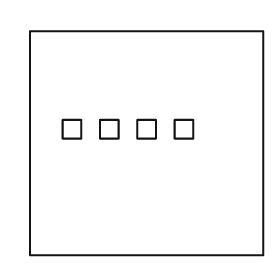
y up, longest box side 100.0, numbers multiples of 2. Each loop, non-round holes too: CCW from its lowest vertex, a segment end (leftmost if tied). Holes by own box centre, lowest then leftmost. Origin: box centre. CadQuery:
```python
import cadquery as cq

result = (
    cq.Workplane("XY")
    .moveTo(-50.0, -48.0)
    .lineTo(50.0, -48.0)
    .lineTo(50.0, 48.0)
    .lineTo(-50.0, 48.0)
    .close()
    .moveTo(-36.0, 2.0)
    .lineTo(-28.0, 2.0)
    .lineTo(-28.0, 10.0)
    .lineTo(-36.0, 10.0)
    .close()
    .moveTo(-20.0, 2.0)
    .lineTo(-12.0, 2.0)
    .lineTo(-12.0, 10.0)
    .lineTo(-20.0, 10.0)
    .close()
    .moveTo(-4.0, 2.0)
    .lineTo(4.0, 2.0)
    .lineTo(4.0, 10.0)
    .lineTo(-4.0, 10.0)
    .close()
    .moveTo(12.0, 2.0)
    .lineTo(20.0, 2.0)
    .lineTo(20.0, 10.0)
    .lineTo(12.0, 10.0)
    .close()
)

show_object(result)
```